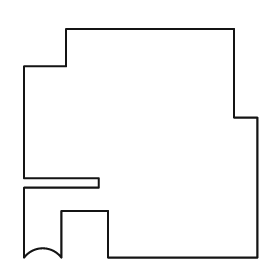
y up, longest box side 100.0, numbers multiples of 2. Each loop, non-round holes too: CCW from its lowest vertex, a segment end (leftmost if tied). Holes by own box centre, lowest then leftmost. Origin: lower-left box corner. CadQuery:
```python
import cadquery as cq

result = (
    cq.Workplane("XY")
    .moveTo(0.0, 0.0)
    .threePointArc((8.0, 4.0), (16.0, 0.0))
    .lineTo(16.0, 20.0)
    .lineTo(36.0, 20.0)
    .lineTo(36.0, 0.0)
    .lineTo(100.0, 0.0)
    .lineTo(100.0, 60.0)
    .lineTo(90.0, 60.0)
    .lineTo(90.0, 98.0)
    .lineTo(18.0, 98.0)
    .lineTo(18.0, 82.0)
    .lineTo(0.0, 82.0)
    .lineTo(0.0, 34.0)
    .lineTo(32.0, 34.0)
    .lineTo(32.0, 30.0)
    .lineTo(0.0, 30.0)
    .close()
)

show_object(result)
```